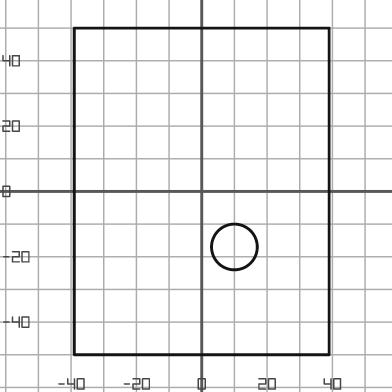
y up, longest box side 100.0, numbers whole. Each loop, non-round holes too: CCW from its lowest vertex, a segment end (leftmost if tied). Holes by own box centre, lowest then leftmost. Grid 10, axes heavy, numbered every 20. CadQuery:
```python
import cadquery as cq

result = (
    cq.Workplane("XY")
    .moveTo(-39.0, -50.0)
    .lineTo(39.0, -50.0)
    .lineTo(39.0, 50.0)
    .lineTo(-39.0, 50.0)
    .close()
    .moveTo(10.0, -17.0)
    .circle(7.0)
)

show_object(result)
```